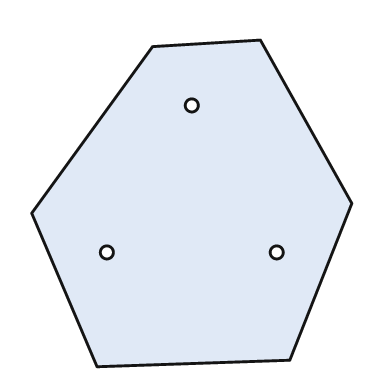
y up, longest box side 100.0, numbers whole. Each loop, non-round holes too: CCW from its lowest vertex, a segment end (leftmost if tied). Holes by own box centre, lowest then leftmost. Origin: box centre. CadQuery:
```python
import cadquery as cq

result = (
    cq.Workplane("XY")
    .moveTo(-29.0, -50.0)
    .lineTo(30.0, -48.0)
    .lineTo(49.0, 0.0)
    .lineTo(21.0, 50.0)
    .lineTo(-12.0, 48.0)
    .lineTo(-49.0, -3.0)
    .close()
    .moveTo(-26.0, -15.0)
    .circle(2.0)
    .moveTo(26.0, -15.0)
    .circle(2.0)
    .moveTo(0.0, 30.0)
    .circle(2.0)
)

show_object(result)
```